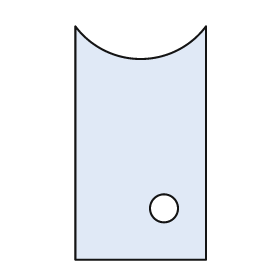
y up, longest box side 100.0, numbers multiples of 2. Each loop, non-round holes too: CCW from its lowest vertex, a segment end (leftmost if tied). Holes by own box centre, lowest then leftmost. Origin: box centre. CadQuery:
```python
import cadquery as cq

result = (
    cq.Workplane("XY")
    .moveTo(-28.0, -50.0)
    .lineTo(28.0, -50.0)
    .lineTo(28.0, 50.0)
    .threePointArc((0.0, 36.0), (-28.0, 50.0))
    .close()
    .moveTo(10.0, -28.0)
    .circle(6.0)
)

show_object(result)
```